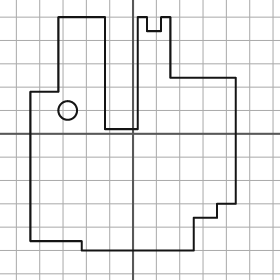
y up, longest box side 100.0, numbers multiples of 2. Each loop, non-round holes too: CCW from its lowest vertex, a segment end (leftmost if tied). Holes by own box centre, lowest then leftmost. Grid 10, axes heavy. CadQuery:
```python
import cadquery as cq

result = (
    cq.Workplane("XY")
    .moveTo(-22.0, -50.0)
    .lineTo(26.0, -50.0)
    .lineTo(26.0, -36.0)
    .lineTo(36.0, -36.0)
    .lineTo(36.0, -30.0)
    .lineTo(44.0, -30.0)
    .lineTo(44.0, 24.0)
    .lineTo(16.0, 24.0)
    .lineTo(16.0, 50.0)
    .lineTo(12.0, 50.0)
    .lineTo(12.0, 44.0)
    .lineTo(6.0, 44.0)
    .lineTo(6.0, 50.0)
    .lineTo(2.0, 50.0)
    .lineTo(2.0, 2.0)
    .lineTo(-12.0, 2.0)
    .lineTo(-12.0, 50.0)
    .lineTo(-32.0, 50.0)
    .lineTo(-32.0, 18.0)
    .lineTo(-44.0, 18.0)
    .lineTo(-44.0, -46.0)
    .lineTo(-22.0, -46.0)
    .close()
    .moveTo(-28.0, 10.0)
    .circle(4.0)
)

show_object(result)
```